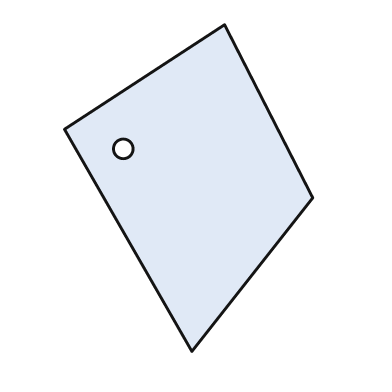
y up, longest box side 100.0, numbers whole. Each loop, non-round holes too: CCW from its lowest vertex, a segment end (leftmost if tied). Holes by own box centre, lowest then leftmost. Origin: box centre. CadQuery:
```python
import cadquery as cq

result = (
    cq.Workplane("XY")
    .moveTo(1.0, -50.0)
    .lineTo(38.0, -3.0)
    .lineTo(11.0, 50.0)
    .lineTo(-38.0, 18.0)
    .close()
    .moveTo(-20.0, 12.0)
    .circle(3.0)
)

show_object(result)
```